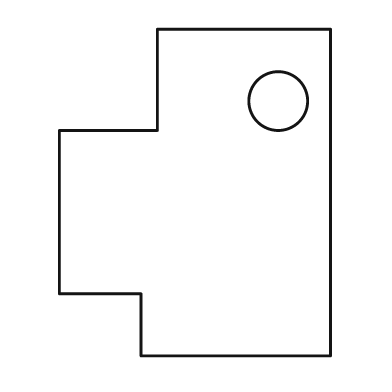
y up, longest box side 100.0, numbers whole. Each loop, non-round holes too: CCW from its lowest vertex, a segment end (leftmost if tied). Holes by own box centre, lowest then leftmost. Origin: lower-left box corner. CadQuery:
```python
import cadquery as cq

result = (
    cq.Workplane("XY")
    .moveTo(25.0, 0.0)
    .lineTo(83.0, 0.0)
    .lineTo(83.0, 100.0)
    .lineTo(30.0, 100.0)
    .lineTo(30.0, 69.0)
    .lineTo(0.0, 69.0)
    .lineTo(0.0, 19.0)
    .lineTo(25.0, 19.0)
    .close()
    .moveTo(67.0, 78.0)
    .circle(9.0)
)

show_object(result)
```